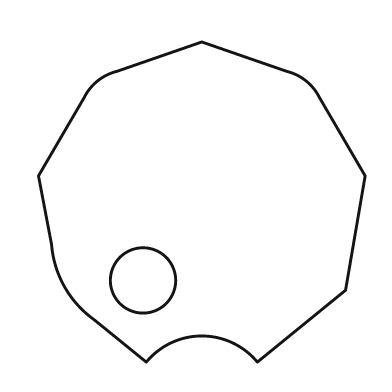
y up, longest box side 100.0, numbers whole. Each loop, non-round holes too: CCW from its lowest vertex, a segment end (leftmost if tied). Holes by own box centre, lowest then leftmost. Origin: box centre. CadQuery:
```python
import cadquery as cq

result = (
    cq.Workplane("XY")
    .moveTo(-17.0, -49.0)
    .threePointArc((0.0, -41.0), (17.0, -49.0))
    .lineTo(44.0, -27.0)
    .lineTo(50.0, 8.0)
    .lineTo(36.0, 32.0)
    .threePointArc((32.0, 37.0), (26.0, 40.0))
    .lineTo(0.0, 49.0)
    .lineTo(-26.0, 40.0)
    .threePointArc((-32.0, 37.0), (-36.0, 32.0))
    .lineTo(-50.0, 8.0)
    .lineTo(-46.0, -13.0)
    .threePointArc((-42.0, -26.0), (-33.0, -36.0))
    .close()
    .moveTo(-18.0, -24.0)
    .circle(10.0)
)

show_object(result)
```